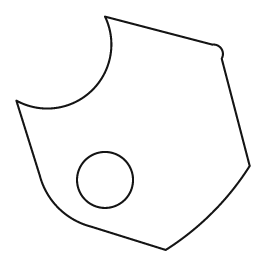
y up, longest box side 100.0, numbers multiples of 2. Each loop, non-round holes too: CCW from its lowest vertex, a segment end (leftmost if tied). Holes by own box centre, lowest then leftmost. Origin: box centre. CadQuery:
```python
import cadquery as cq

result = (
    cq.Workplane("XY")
    .moveTo(14.0, -50.0)
    .threePointArc((34.0, -34.0), (50.0, -14.0))
    .lineTo(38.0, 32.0)
    .threePointArc((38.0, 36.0), (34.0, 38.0))
    .lineTo(-12.0, 50.0)
    .threePointArc((-18.0, 18.0), (-50.0, 14.0))
    .lineTo(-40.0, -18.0)
    .threePointArc((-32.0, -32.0), (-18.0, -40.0))
    .close()
    .moveTo(-12.0, -20.0)
    .circle(12.0)
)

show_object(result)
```